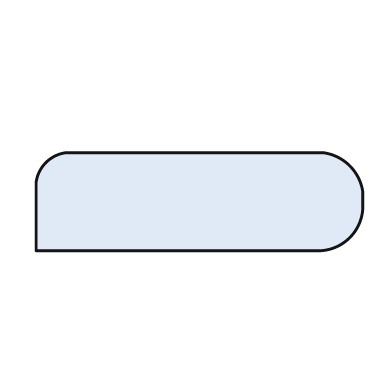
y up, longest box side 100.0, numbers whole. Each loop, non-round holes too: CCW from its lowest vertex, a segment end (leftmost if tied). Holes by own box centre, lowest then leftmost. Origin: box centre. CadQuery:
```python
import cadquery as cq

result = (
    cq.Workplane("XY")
    .moveTo(-50.0, -15.0)
    .lineTo(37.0, -15.0)
    .threePointArc((46.0, -11.0), (50.0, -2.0))
    .lineTo(50.0, 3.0)
    .threePointArc((46.0, 11.0), (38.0, 15.0))
    .lineTo(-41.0, 15.0)
    .threePointArc((-47.0, 12.0), (-50.0, 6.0))
    .close()
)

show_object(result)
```